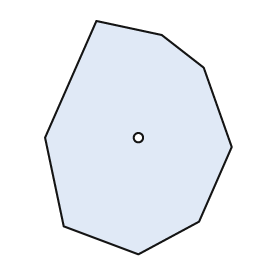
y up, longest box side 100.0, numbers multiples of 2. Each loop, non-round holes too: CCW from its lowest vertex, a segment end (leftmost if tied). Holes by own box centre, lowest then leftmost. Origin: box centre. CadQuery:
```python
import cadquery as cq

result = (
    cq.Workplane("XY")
    .moveTo(0.0, -50.0)
    .lineTo(26.0, -36.0)
    .lineTo(40.0, -4.0)
    .lineTo(28.0, 30.0)
    .lineTo(10.0, 44.0)
    .lineTo(-18.0, 50.0)
    .lineTo(-40.0, 0.0)
    .lineTo(-32.0, -38.0)
    .close()
    .moveTo(0.0, 0.0)
    .circle(2.0)
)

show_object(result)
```